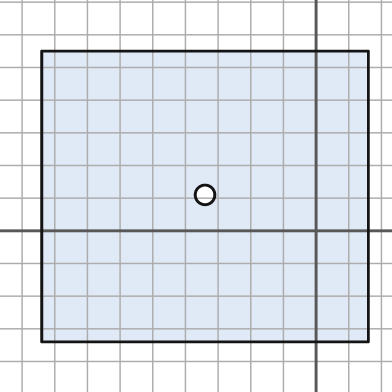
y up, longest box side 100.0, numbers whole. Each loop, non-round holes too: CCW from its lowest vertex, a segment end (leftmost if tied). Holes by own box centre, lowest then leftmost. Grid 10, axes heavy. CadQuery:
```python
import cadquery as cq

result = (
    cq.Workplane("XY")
    .moveTo(-84.0, -34.0)
    .lineTo(16.0, -34.0)
    .lineTo(16.0, 55.0)
    .lineTo(-84.0, 55.0)
    .close()
    .moveTo(-34.0, 11.0)
    .circle(3.0)
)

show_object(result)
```